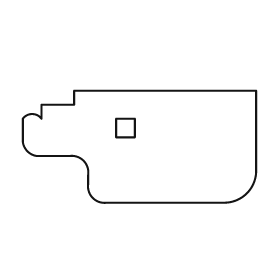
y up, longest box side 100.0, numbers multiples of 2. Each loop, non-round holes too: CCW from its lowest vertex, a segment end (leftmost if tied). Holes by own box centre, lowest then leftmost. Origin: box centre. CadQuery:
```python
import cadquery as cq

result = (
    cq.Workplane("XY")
    .moveTo(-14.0, -24.0)
    .lineTo(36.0, -24.0)
    .threePointArc((46.0, -20.0), (50.0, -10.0))
    .lineTo(50.0, 24.0)
    .lineTo(-28.0, 24.0)
    .lineTo(-28.0, 18.0)
    .lineTo(-42.0, 18.0)
    .lineTo(-42.0, 12.0)
    .threePointArc((-46.0, 14.0), (-50.0, 12.0))
    .lineTo(-50.0, 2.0)
    .threePointArc((-48.0, -2.0), (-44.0, -4.0))
    .lineTo(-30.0, -4.0)
    .threePointArc((-24.0, -6.0), (-22.0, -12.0))
    .lineTo(-22.0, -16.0)
    .threePointArc((-20.0, -22.0), (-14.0, -24.0))
    .close()
    .moveTo(-10.0, 4.0)
    .lineTo(-2.0, 4.0)
    .lineTo(-2.0, 12.0)
    .lineTo(-10.0, 12.0)
    .close()
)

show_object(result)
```